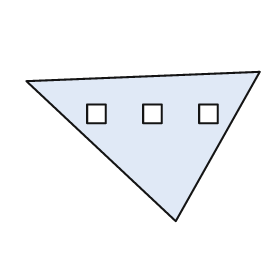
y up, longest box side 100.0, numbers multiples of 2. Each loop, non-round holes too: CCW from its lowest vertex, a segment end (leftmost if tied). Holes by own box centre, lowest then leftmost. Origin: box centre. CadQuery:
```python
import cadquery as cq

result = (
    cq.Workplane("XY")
    .moveTo(14.0, -32.0)
    .lineTo(50.0, 32.0)
    .lineTo(-50.0, 28.0)
    .close()
    .moveTo(-24.0, 10.0)
    .lineTo(-16.0, 10.0)
    .lineTo(-16.0, 18.0)
    .lineTo(-24.0, 18.0)
    .close()
    .moveTo(0.0, 10.0)
    .lineTo(8.0, 10.0)
    .lineTo(8.0, 18.0)
    .lineTo(0.0, 18.0)
    .close()
    .moveTo(24.0, 10.0)
    .lineTo(32.0, 10.0)
    .lineTo(32.0, 18.0)
    .lineTo(24.0, 18.0)
    .close()
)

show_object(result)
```